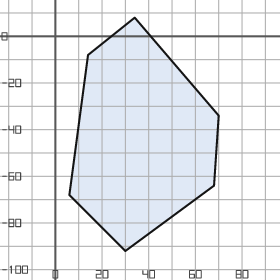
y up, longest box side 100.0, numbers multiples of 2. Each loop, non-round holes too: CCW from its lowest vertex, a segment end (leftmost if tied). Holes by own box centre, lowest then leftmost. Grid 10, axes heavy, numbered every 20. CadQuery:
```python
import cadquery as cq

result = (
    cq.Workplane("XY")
    .moveTo(30.0, -92.0)
    .lineTo(68.0, -64.0)
    .lineTo(70.0, -34.0)
    .lineTo(34.0, 8.0)
    .lineTo(14.0, -8.0)
    .lineTo(6.0, -68.0)
    .close()
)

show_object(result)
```